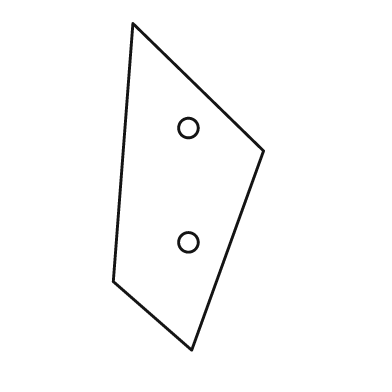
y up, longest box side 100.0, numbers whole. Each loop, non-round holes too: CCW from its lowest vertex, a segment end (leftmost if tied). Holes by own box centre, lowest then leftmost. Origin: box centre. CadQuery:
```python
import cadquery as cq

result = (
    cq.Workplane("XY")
    .moveTo(1.0, -50.0)
    .lineTo(23.0, 11.0)
    .lineTo(-17.0, 50.0)
    .lineTo(-23.0, -29.0)
    .close()
    .moveTo(0.0, -17.0)
    .circle(3.0)
    .moveTo(0.0, 18.0)
    .circle(3.0)
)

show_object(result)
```